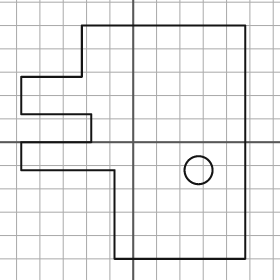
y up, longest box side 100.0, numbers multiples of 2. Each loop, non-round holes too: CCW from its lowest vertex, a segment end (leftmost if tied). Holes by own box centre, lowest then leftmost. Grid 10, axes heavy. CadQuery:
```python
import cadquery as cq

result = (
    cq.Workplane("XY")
    .moveTo(-8.0, -50.0)
    .lineTo(48.0, -50.0)
    .lineTo(48.0, 50.0)
    .lineTo(-22.0, 50.0)
    .lineTo(-22.0, 28.0)
    .lineTo(-48.0, 28.0)
    .lineTo(-48.0, 12.0)
    .lineTo(-18.0, 12.0)
    .lineTo(-18.0, 0.0)
    .lineTo(-48.0, 0.0)
    .lineTo(-48.0, -12.0)
    .lineTo(-8.0, -12.0)
    .close()
    .moveTo(28.0, -12.0)
    .circle(6.0)
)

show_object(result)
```